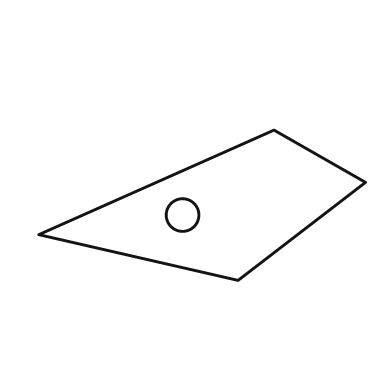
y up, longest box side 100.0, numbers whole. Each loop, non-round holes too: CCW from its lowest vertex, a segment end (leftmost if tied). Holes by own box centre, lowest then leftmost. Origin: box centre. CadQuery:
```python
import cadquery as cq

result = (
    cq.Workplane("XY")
    .moveTo(11.0, -23.0)
    .lineTo(50.0, 7.0)
    .lineTo(22.0, 23.0)
    .lineTo(-50.0, -9.0)
    .close()
    .moveTo(-6.0, -3.0)
    .circle(5.0)
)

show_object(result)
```